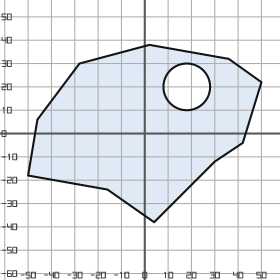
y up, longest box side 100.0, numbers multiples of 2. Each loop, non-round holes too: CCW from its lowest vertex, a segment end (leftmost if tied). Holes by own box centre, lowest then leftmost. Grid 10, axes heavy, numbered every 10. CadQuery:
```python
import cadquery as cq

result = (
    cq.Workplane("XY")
    .moveTo(4.0, -38.0)
    .lineTo(30.0, -12.0)
    .lineTo(42.0, -4.0)
    .lineTo(50.0, 22.0)
    .lineTo(36.0, 32.0)
    .lineTo(2.0, 38.0)
    .lineTo(-28.0, 30.0)
    .lineTo(-46.0, 6.0)
    .lineTo(-50.0, -18.0)
    .lineTo(-16.0, -24.0)
    .close()
    .moveTo(18.0, 20.0)
    .circle(10.0)
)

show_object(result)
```